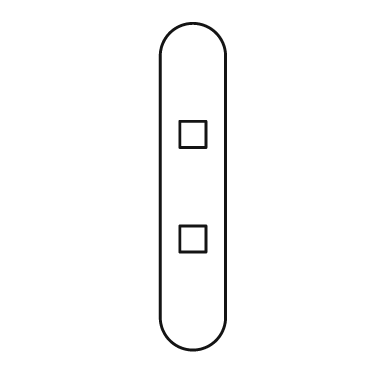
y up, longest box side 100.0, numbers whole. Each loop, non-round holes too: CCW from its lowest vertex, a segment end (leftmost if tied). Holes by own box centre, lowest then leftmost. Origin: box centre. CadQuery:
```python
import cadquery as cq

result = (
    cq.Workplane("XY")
    .moveTo(-10.0, -40.0)
    .threePointArc((0.0, -50.0), (10.0, -40.0))
    .lineTo(10.0, 40.0)
    .threePointArc((0.0, 50.0), (-10.0, 40.0))
    .close()
    .moveTo(-4.0, -20.0)
    .lineTo(4.0, -20.0)
    .lineTo(4.0, -12.0)
    .lineTo(-4.0, -12.0)
    .close()
    .moveTo(-4.0, 12.0)
    .lineTo(4.0, 12.0)
    .lineTo(4.0, 20.0)
    .lineTo(-4.0, 20.0)
    .close()
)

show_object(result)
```